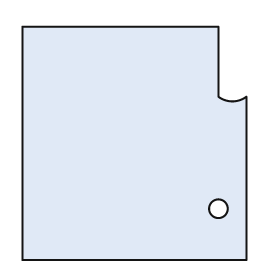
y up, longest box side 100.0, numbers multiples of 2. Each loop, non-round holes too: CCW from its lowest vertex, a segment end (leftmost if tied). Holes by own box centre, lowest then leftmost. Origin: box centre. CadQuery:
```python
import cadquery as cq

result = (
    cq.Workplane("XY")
    .moveTo(-48.0, -50.0)
    .lineTo(48.0, -50.0)
    .lineTo(48.0, 20.0)
    .threePointArc((42.0, 18.0), (36.0, 20.0))
    .lineTo(36.0, 50.0)
    .lineTo(-48.0, 50.0)
    .close()
    .moveTo(36.0, -28.0)
    .circle(4.0)
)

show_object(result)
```